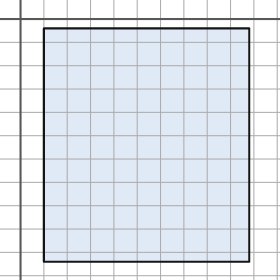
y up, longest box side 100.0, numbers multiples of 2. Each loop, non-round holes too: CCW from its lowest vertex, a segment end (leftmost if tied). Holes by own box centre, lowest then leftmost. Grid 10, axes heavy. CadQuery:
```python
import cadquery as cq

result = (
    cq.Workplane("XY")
    .moveTo(10.0, -104.0)
    .lineTo(98.0, -104.0)
    .lineTo(98.0, -4.0)
    .lineTo(10.0, -4.0)
    .close()
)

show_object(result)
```